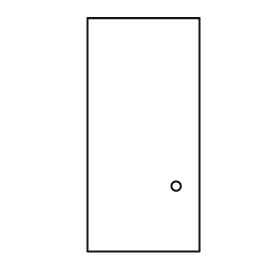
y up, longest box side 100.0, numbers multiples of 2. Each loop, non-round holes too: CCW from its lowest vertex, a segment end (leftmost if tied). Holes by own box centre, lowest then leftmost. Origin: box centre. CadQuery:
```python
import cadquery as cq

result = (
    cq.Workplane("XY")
    .moveTo(-24.0, -50.0)
    .lineTo(24.0, -50.0)
    .lineTo(24.0, 50.0)
    .lineTo(-24.0, 50.0)
    .close()
    .moveTo(14.0, -22.0)
    .circle(2.0)
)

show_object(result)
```